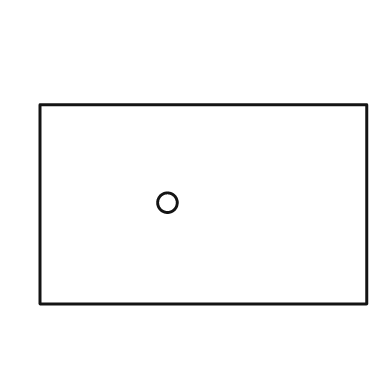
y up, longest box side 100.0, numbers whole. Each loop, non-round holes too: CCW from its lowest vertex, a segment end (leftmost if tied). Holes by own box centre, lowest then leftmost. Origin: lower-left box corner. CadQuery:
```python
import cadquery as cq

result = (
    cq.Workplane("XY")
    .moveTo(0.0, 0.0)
    .lineTo(100.0, 0.0)
    .lineTo(100.0, 61.0)
    .lineTo(0.0, 61.0)
    .close()
    .moveTo(39.0, 31.0)
    .circle(3.0)
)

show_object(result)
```